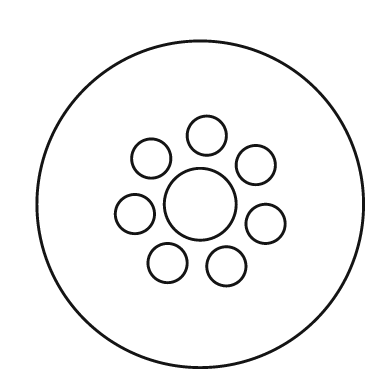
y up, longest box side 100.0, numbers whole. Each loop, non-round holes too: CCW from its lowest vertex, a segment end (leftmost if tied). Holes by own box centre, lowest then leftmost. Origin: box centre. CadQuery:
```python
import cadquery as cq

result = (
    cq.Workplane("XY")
    .moveTo(0.0, 0.0)
    .circle(50.0)
    .moveTo(8.0, -19.0)
    .circle(6.0)
    .moveTo(-10.0, -18.0)
    .circle(6.0)
    .moveTo(20.0, -6.0)
    .circle(6.0)
    .moveTo(-20.0, -3.0)
    .circle(6.0)
    .moveTo(0.0, 0.0)
    .circle(11.0)
    .moveTo(17.0, 12.0)
    .circle(6.0)
    .moveTo(-15.0, 14.0)
    .circle(6.0)
    .moveTo(2.0, 21.0)
    .circle(6.0)
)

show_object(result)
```